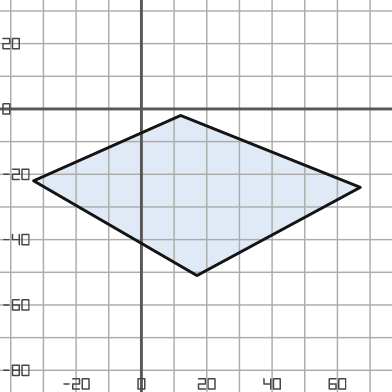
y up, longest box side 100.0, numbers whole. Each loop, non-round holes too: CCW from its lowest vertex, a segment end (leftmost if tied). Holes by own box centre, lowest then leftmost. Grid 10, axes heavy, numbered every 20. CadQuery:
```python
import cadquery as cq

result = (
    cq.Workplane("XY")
    .moveTo(17.0, -51.0)
    .lineTo(67.0, -24.0)
    .lineTo(12.0, -2.0)
    .lineTo(-33.0, -22.0)
    .close()
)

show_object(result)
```